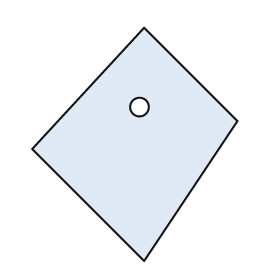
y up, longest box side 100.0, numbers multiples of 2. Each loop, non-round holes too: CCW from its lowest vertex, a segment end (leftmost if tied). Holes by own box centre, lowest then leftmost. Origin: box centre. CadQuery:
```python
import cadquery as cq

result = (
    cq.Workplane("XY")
    .moveTo(4.0, -50.0)
    .lineTo(44.0, 10.0)
    .lineTo(4.0, 50.0)
    .lineTo(-44.0, -2.0)
    .close()
    .moveTo(2.0, 16.0)
    .circle(4.0)
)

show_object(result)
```